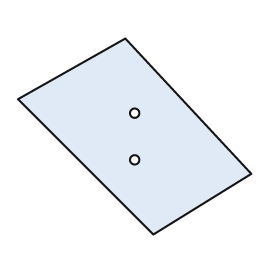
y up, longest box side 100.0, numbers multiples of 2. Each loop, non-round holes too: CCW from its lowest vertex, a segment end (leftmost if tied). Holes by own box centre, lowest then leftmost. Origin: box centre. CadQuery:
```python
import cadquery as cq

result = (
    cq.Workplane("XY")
    .moveTo(8.0, -42.0)
    .lineTo(50.0, -16.0)
    .lineTo(-4.0, 42.0)
    .lineTo(-50.0, 16.0)
    .close()
    .moveTo(0.0, -10.0)
    .circle(2.0)
    .moveTo(0.0, 10.0)
    .circle(2.0)
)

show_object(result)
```